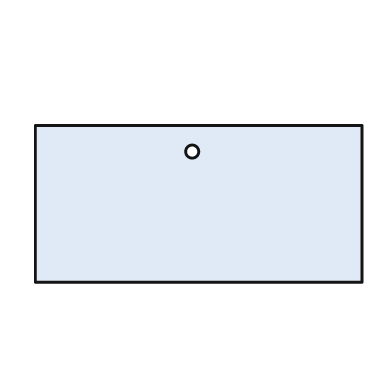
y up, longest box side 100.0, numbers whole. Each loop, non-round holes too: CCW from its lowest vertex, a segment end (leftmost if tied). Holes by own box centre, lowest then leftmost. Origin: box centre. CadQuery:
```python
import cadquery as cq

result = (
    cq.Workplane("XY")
    .moveTo(-50.0, -24.0)
    .lineTo(50.0, -24.0)
    .lineTo(50.0, 24.0)
    .lineTo(-50.0, 24.0)
    .close()
    .moveTo(-2.0, 16.0)
    .circle(2.0)
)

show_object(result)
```